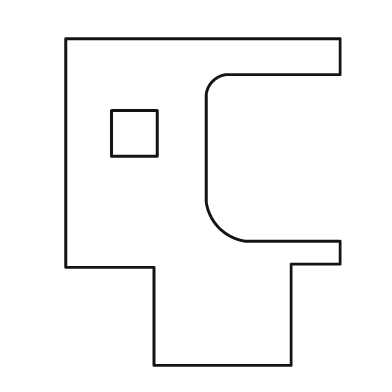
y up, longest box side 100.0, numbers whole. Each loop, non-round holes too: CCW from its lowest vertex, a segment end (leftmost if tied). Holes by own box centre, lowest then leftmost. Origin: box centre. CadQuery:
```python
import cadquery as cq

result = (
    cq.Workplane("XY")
    .moveTo(-15.0, -50.0)
    .lineTo(27.0, -50.0)
    .lineTo(27.0, -19.0)
    .lineTo(42.0, -19.0)
    .lineTo(42.0, -12.0)
    .lineTo(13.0, -12.0)
    .threePointArc((5.0, -8.0), (1.0, 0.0))
    .lineTo(1.0, 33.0)
    .threePointArc((3.0, 37.0), (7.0, 39.0))
    .lineTo(42.0, 39.0)
    .lineTo(42.0, 50.0)
    .lineTo(-42.0, 50.0)
    .lineTo(-42.0, -20.0)
    .lineTo(-15.0, -20.0)
    .close()
    .moveTo(-28.0, 14.0)
    .lineTo(-14.0, 14.0)
    .lineTo(-14.0, 28.0)
    .lineTo(-28.0, 28.0)
    .close()
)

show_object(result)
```